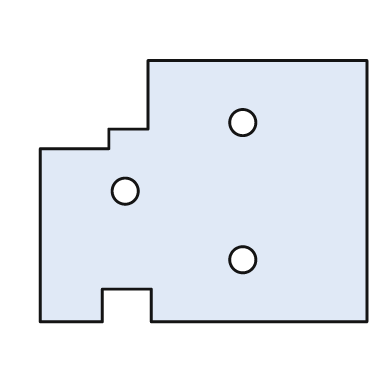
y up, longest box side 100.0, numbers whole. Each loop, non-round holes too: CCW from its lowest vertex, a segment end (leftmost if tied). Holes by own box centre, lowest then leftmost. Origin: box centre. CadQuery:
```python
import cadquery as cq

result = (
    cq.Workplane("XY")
    .moveTo(-50.0, -40.0)
    .lineTo(-31.0, -40.0)
    .lineTo(-31.0, -30.0)
    .lineTo(-16.0, -30.0)
    .lineTo(-16.0, -40.0)
    .lineTo(50.0, -40.0)
    .lineTo(50.0, 40.0)
    .lineTo(-17.0, 40.0)
    .lineTo(-17.0, 19.0)
    .lineTo(-29.0, 19.0)
    .lineTo(-29.0, 13.0)
    .lineTo(-50.0, 13.0)
    .close()
    .moveTo(12.0, -21.0)
    .circle(4.0)
    .moveTo(-24.0, 0.0)
    .circle(4.0)
    .moveTo(12.0, 21.0)
    .circle(4.0)
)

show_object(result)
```